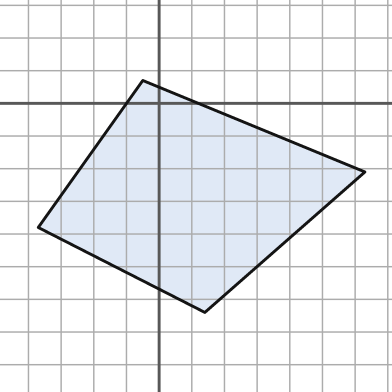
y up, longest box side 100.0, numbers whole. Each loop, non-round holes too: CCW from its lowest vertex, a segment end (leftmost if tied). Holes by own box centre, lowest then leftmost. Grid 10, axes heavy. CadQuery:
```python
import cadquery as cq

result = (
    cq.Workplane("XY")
    .moveTo(14.0, -64.0)
    .lineTo(63.0, -21.0)
    .lineTo(-5.0, 7.0)
    .lineTo(-37.0, -38.0)
    .close()
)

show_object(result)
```